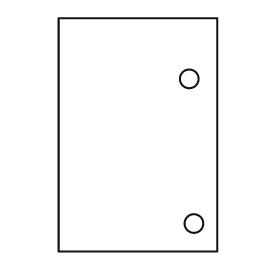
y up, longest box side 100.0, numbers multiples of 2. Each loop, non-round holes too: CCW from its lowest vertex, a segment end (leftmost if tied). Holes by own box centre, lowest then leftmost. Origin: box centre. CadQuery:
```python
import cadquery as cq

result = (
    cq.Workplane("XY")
    .moveTo(-34.0, -50.0)
    .lineTo(34.0, -50.0)
    .lineTo(34.0, 50.0)
    .lineTo(-34.0, 50.0)
    .close()
    .moveTo(24.0, -38.0)
    .circle(4.0)
    .moveTo(22.0, 24.0)
    .circle(4.0)
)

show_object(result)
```